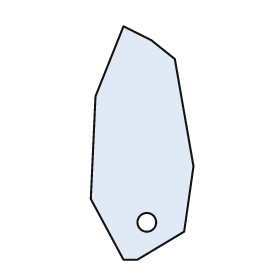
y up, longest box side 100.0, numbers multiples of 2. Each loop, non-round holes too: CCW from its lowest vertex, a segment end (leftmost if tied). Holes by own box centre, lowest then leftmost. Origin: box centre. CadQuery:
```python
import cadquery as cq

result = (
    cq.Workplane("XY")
    .moveTo(-8.0, -50.0)
    .lineTo(-2.0, -50.0)
    .lineTo(18.0, -38.0)
    .lineTo(22.0, -10.0)
    .lineTo(14.0, 36.0)
    .lineTo(4.0, 44.0)
    .lineTo(-8.0, 50.0)
    .lineTo(-20.0, 20.0)
    .lineTo(-22.0, -24.0)
    .close()
    .moveTo(2.0, -34.0)
    .circle(4.0)
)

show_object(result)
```